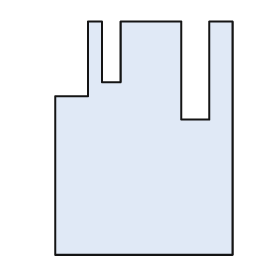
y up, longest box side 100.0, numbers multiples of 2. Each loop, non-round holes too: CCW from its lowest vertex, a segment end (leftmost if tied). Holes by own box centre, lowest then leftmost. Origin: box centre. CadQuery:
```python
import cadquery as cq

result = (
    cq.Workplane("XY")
    .moveTo(-38.0, -50.0)
    .lineTo(38.0, -50.0)
    .lineTo(38.0, 50.0)
    .lineTo(28.0, 50.0)
    .lineTo(28.0, 8.0)
    .lineTo(16.0, 8.0)
    .lineTo(16.0, 50.0)
    .lineTo(-10.0, 50.0)
    .lineTo(-10.0, 24.0)
    .lineTo(-18.0, 24.0)
    .lineTo(-18.0, 50.0)
    .lineTo(-24.0, 50.0)
    .lineTo(-24.0, 18.0)
    .lineTo(-38.0, 18.0)
    .close()
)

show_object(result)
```